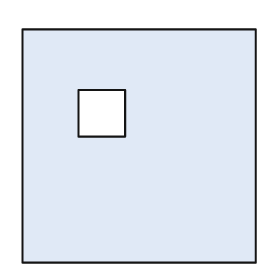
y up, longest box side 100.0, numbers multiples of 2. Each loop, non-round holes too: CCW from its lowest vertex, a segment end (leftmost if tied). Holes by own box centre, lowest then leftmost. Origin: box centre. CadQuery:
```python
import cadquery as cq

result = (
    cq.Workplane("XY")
    .moveTo(-50.0, -50.0)
    .lineTo(50.0, -50.0)
    .lineTo(50.0, 50.0)
    .lineTo(-50.0, 50.0)
    .close()
    .moveTo(-26.0, 4.0)
    .lineTo(-6.0, 4.0)
    .lineTo(-6.0, 24.0)
    .lineTo(-26.0, 24.0)
    .close()
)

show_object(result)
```